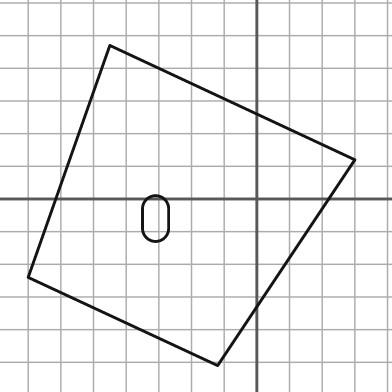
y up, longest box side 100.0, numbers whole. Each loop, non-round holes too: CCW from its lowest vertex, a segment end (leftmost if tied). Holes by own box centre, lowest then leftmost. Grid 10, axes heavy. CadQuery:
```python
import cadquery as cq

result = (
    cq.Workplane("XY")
    .moveTo(-12.0, -51.0)
    .lineTo(30.0, 12.0)
    .lineTo(-45.0, 47.0)
    .lineTo(-70.0, -24.0)
    .close()
    .moveTo(-35.0, -9.0)
    .threePointArc((-31.0, -13.0), (-27.0, -9.0))
    .lineTo(-27.0, -3.0)
    .threePointArc((-31.0, 1.0), (-35.0, -3.0))
    .close()
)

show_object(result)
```